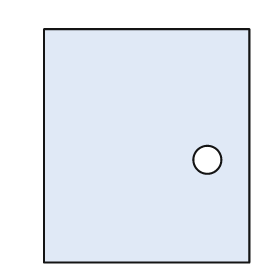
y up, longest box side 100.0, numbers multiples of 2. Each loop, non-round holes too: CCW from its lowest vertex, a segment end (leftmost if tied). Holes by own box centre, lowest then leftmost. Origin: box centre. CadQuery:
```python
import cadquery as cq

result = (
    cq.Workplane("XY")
    .moveTo(-44.0, -50.0)
    .lineTo(44.0, -50.0)
    .lineTo(44.0, 50.0)
    .lineTo(-44.0, 50.0)
    .close()
    .moveTo(26.0, -6.0)
    .circle(6.0)
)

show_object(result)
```